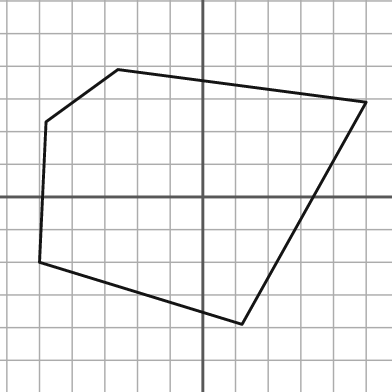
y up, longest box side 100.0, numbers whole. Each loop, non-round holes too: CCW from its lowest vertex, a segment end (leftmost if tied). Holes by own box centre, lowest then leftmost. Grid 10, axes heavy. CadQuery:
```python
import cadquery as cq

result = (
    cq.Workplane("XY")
    .moveTo(12.0, -39.0)
    .lineTo(50.0, 29.0)
    .lineTo(-26.0, 39.0)
    .lineTo(-48.0, 23.0)
    .lineTo(-50.0, -20.0)
    .close()
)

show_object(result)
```